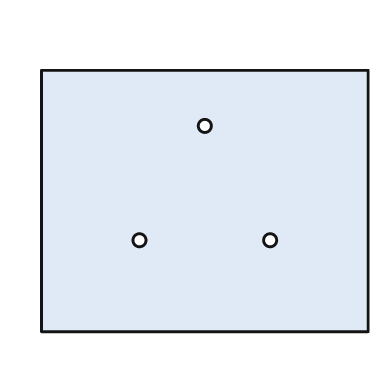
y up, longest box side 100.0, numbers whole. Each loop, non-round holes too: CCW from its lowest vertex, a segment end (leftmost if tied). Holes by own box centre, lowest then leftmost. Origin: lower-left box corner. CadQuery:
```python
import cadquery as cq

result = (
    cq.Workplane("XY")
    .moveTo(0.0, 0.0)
    .lineTo(100.0, 0.0)
    .lineTo(100.0, 80.0)
    .lineTo(0.0, 80.0)
    .close()
    .moveTo(30.0, 28.0)
    .circle(2.0)
    .moveTo(70.0, 28.0)
    .circle(2.0)
    .moveTo(50.0, 63.0)
    .circle(2.0)
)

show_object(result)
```